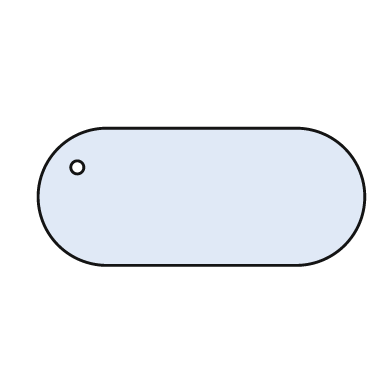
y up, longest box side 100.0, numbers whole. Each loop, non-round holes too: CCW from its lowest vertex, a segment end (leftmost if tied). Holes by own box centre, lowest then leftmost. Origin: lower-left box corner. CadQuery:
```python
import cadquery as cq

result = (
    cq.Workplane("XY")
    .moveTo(21.0, 0.0)
    .lineTo(79.0, 0.0)
    .threePointArc((100.0, 21.0), (79.0, 42.0))
    .lineTo(21.0, 42.0)
    .threePointArc((0.0, 21.0), (21.0, 0.0))
    .close()
    .moveTo(12.0, 30.0)
    .circle(2.0)
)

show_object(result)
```